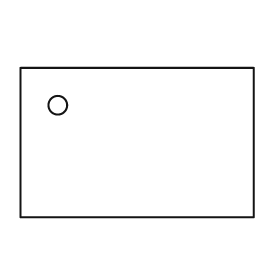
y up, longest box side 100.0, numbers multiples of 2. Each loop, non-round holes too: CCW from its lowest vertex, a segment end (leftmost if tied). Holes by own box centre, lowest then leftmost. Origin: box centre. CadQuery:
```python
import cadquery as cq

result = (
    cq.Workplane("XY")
    .moveTo(-50.0, -32.0)
    .lineTo(50.0, -32.0)
    .lineTo(50.0, 32.0)
    .lineTo(-50.0, 32.0)
    .close()
    .moveTo(-34.0, 16.0)
    .circle(4.0)
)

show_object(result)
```